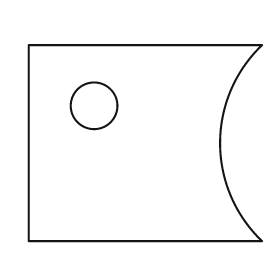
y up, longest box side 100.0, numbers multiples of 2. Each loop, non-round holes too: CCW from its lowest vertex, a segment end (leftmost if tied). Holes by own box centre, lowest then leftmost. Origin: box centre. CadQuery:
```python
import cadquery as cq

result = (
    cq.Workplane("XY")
    .moveTo(-50.0, -42.0)
    .lineTo(50.0, -42.0)
    .threePointArc((32.0, 0.0), (50.0, 42.0))
    .lineTo(-50.0, 42.0)
    .close()
    .moveTo(-22.0, 16.0)
    .circle(10.0)
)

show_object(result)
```